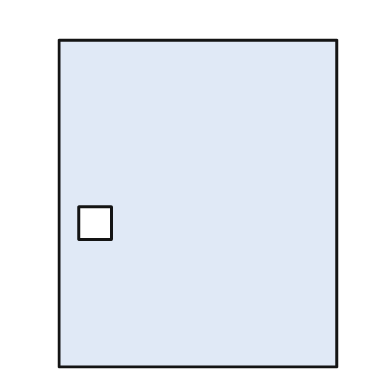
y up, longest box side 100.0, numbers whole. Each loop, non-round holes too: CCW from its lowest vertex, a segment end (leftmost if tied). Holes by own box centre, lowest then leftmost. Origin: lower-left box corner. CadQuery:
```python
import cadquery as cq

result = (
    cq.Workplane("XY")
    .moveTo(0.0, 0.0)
    .lineTo(85.0, 0.0)
    .lineTo(85.0, 100.0)
    .lineTo(0.0, 100.0)
    .close()
    .moveTo(6.0, 39.0)
    .lineTo(16.0, 39.0)
    .lineTo(16.0, 49.0)
    .lineTo(6.0, 49.0)
    .close()
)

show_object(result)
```